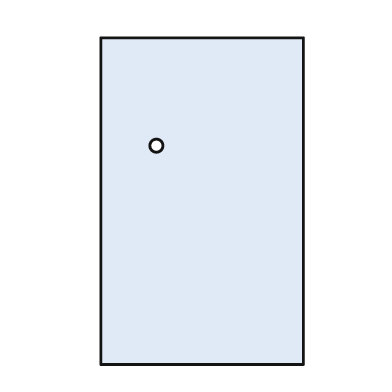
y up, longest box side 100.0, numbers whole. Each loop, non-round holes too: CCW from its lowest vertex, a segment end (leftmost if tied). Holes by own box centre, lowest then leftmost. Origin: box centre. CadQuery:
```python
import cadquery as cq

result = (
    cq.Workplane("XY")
    .moveTo(-31.0, -50.0)
    .lineTo(31.0, -50.0)
    .lineTo(31.0, 50.0)
    .lineTo(-31.0, 50.0)
    .close()
    .moveTo(-14.0, 17.0)
    .circle(2.0)
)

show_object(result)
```